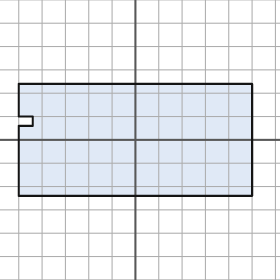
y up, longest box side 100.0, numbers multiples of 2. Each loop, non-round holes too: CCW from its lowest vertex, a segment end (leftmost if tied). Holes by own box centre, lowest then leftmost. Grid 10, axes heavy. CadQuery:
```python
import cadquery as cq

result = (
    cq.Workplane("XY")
    .moveTo(-50.0, -24.0)
    .lineTo(50.0, -24.0)
    .lineTo(50.0, 24.0)
    .lineTo(-50.0, 24.0)
    .lineTo(-50.0, 10.0)
    .lineTo(-44.0, 10.0)
    .lineTo(-44.0, 6.0)
    .lineTo(-50.0, 6.0)
    .close()
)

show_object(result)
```